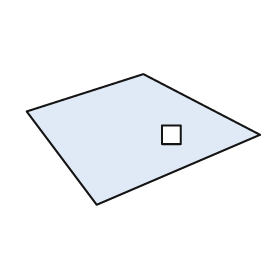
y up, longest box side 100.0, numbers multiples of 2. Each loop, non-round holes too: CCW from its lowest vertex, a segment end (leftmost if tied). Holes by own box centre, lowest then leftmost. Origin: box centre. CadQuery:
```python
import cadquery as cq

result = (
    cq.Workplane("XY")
    .moveTo(-20.0, -28.0)
    .lineTo(50.0, 2.0)
    .lineTo(0.0, 28.0)
    .lineTo(-50.0, 12.0)
    .close()
    .moveTo(8.0, -2.0)
    .lineTo(16.0, -2.0)
    .lineTo(16.0, 6.0)
    .lineTo(8.0, 6.0)
    .close()
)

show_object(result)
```